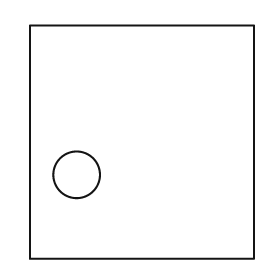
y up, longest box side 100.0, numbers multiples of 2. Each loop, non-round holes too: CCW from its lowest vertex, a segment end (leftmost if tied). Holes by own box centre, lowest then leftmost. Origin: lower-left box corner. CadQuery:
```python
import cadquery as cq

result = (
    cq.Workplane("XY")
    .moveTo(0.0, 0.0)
    .lineTo(96.0, 0.0)
    .lineTo(96.0, 100.0)
    .lineTo(0.0, 100.0)
    .close()
    .moveTo(20.0, 36.0)
    .circle(10.0)
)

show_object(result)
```